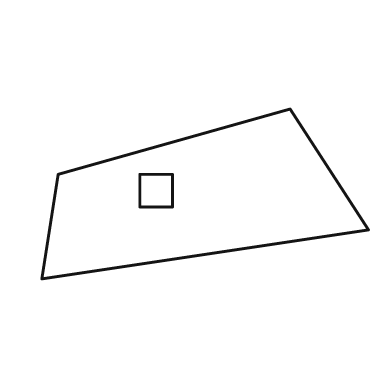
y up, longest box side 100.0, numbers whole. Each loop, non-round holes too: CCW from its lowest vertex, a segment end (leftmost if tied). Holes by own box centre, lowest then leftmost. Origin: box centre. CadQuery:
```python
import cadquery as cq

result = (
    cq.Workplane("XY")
    .moveTo(-50.0, -26.0)
    .lineTo(50.0, -11.0)
    .lineTo(26.0, 26.0)
    .lineTo(-45.0, 6.0)
    .close()
    .moveTo(-20.0, -4.0)
    .lineTo(-10.0, -4.0)
    .lineTo(-10.0, 6.0)
    .lineTo(-20.0, 6.0)
    .close()
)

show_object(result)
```